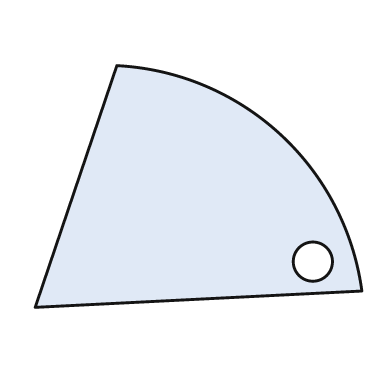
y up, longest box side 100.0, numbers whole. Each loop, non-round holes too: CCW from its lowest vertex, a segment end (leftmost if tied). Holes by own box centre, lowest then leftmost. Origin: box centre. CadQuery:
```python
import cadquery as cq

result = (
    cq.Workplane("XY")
    .moveTo(-50.0, -37.0)
    .lineTo(50.0, -32.0)
    .threePointArc((25.0, 16.0), (-25.0, 37.0))
    .close()
    .moveTo(35.0, -23.0)
    .circle(6.0)
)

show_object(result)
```